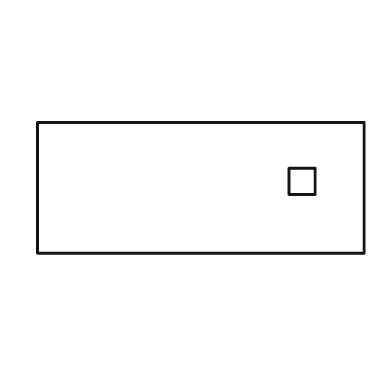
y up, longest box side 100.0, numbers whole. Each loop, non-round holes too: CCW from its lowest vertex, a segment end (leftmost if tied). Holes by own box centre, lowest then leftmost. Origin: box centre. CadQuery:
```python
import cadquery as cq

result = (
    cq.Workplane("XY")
    .moveTo(-50.0, -20.0)
    .lineTo(50.0, -20.0)
    .lineTo(50.0, 20.0)
    .lineTo(-50.0, 20.0)
    .close()
    .moveTo(27.0, -2.0)
    .lineTo(35.0, -2.0)
    .lineTo(35.0, 6.0)
    .lineTo(27.0, 6.0)
    .close()
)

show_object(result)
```